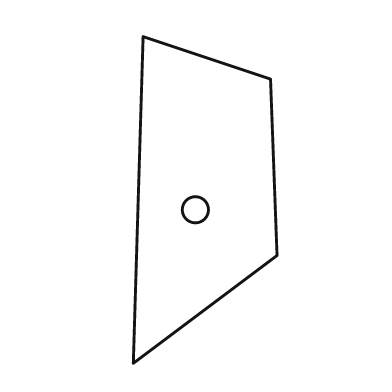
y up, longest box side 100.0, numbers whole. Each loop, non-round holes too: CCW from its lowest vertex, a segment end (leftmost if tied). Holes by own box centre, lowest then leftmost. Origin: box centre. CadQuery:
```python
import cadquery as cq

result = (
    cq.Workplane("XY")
    .moveTo(-22.0, -50.0)
    .lineTo(22.0, -17.0)
    .lineTo(20.0, 37.0)
    .lineTo(-19.0, 50.0)
    .close()
    .moveTo(-3.0, -3.0)
    .circle(4.0)
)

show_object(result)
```